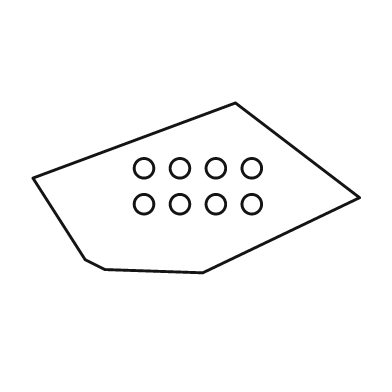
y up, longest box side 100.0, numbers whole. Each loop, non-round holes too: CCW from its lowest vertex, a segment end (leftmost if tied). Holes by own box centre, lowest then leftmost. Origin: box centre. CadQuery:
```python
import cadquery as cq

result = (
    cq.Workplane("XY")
    .moveTo(2.0, -26.0)
    .lineTo(50.0, -3.0)
    .lineTo(12.0, 26.0)
    .lineTo(-50.0, 3.0)
    .lineTo(-34.0, -22.0)
    .lineTo(-28.0, -25.0)
    .close()
    .moveTo(-16.0, -5.0)
    .circle(3.0)
    .moveTo(-5.0, -5.0)
    .circle(3.0)
    .moveTo(6.0, -5.0)
    .circle(3.0)
    .moveTo(17.0, -5.0)
    .circle(3.0)
    .moveTo(-16.0, 6.0)
    .circle(3.0)
    .moveTo(-5.0, 6.0)
    .circle(3.0)
    .moveTo(6.0, 6.0)
    .circle(3.0)
    .moveTo(17.0, 6.0)
    .circle(3.0)
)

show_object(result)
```